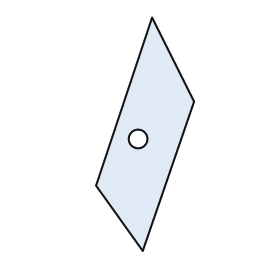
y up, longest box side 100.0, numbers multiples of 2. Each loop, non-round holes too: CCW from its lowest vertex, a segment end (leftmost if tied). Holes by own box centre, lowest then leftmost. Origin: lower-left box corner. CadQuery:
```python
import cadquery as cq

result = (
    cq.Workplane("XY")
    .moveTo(20.0, 0.0)
    .lineTo(42.0, 64.0)
    .lineTo(24.0, 100.0)
    .lineTo(0.0, 28.0)
    .close()
    .moveTo(18.0, 48.0)
    .circle(4.0)
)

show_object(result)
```